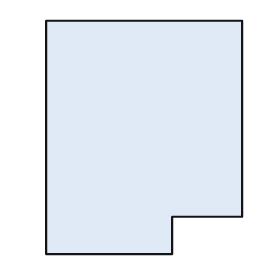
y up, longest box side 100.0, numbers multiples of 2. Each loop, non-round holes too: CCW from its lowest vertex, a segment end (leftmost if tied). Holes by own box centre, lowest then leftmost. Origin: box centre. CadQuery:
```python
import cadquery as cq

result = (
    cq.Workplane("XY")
    .moveTo(-42.0, -50.0)
    .lineTo(12.0, -50.0)
    .lineTo(12.0, -34.0)
    .lineTo(42.0, -34.0)
    .lineTo(42.0, 50.0)
    .lineTo(-42.0, 50.0)
    .close()
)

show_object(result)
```